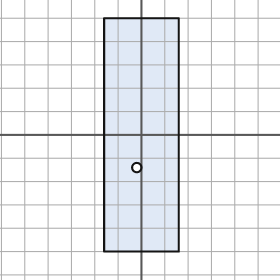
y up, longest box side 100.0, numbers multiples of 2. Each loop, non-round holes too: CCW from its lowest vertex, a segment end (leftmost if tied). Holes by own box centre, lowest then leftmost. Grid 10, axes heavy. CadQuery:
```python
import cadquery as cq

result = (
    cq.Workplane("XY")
    .moveTo(-16.0, -50.0)
    .lineTo(16.0, -50.0)
    .lineTo(16.0, 50.0)
    .lineTo(-16.0, 50.0)
    .close()
    .moveTo(-2.0, -14.0)
    .circle(2.0)
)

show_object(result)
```